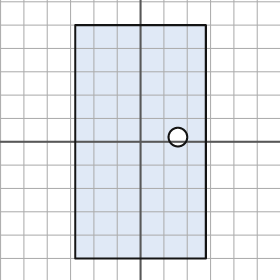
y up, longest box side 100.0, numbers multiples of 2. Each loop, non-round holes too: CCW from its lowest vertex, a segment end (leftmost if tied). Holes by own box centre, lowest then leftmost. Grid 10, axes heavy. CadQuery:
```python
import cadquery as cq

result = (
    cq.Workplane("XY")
    .moveTo(-28.0, -50.0)
    .lineTo(28.0, -50.0)
    .lineTo(28.0, 50.0)
    .lineTo(-28.0, 50.0)
    .close()
    .moveTo(16.0, 2.0)
    .circle(4.0)
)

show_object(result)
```